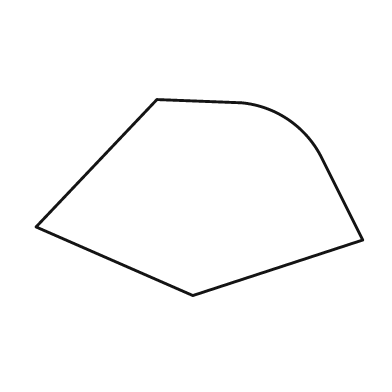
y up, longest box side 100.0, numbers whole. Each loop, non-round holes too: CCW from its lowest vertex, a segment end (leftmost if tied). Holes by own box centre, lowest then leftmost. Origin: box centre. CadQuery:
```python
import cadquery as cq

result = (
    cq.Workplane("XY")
    .moveTo(-2.0, -30.0)
    .lineTo(50.0, -13.0)
    .lineTo(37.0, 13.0)
    .threePointArc((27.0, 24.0), (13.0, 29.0))
    .lineTo(-13.0, 30.0)
    .lineTo(-50.0, -9.0)
    .close()
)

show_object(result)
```